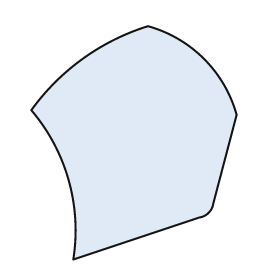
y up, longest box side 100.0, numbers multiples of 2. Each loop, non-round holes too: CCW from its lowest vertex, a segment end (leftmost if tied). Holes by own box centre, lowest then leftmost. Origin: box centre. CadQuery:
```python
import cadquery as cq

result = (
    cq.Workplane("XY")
    .moveTo(-26.0, -50.0)
    .lineTo(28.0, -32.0)
    .threePointArc((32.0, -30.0), (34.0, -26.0))
    .lineTo(44.0, 12.0)
    .threePointArc((30.0, 36.0), (6.0, 50.0))
    .threePointArc((-22.0, 36.0), (-44.0, 14.0))
    .threePointArc((-28.0, -16.0), (-26.0, -50.0))
    .close()
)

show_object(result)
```